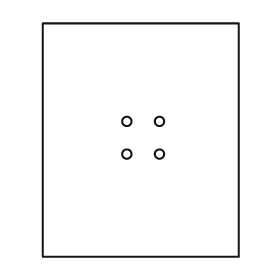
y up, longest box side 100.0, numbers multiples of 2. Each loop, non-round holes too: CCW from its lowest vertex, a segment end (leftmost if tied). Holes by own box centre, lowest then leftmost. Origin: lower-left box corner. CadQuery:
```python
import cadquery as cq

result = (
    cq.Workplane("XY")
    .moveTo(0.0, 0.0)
    .lineTo(84.0, 0.0)
    .lineTo(84.0, 100.0)
    .lineTo(0.0, 100.0)
    .close()
    .moveTo(36.0, 44.0)
    .circle(2.0)
    .moveTo(50.0, 44.0)
    .circle(2.0)
    .moveTo(36.0, 58.0)
    .circle(2.0)
    .moveTo(50.0, 58.0)
    .circle(2.0)
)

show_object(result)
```